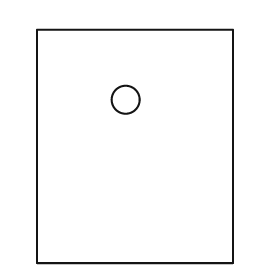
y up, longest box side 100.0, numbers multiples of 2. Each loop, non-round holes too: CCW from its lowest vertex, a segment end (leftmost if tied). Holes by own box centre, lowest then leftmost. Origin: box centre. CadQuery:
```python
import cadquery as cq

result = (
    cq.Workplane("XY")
    .moveTo(-42.0, -50.0)
    .lineTo(42.0, -50.0)
    .lineTo(42.0, 50.0)
    .lineTo(-42.0, 50.0)
    .close()
    .moveTo(-4.0, 20.0)
    .circle(6.0)
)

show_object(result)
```